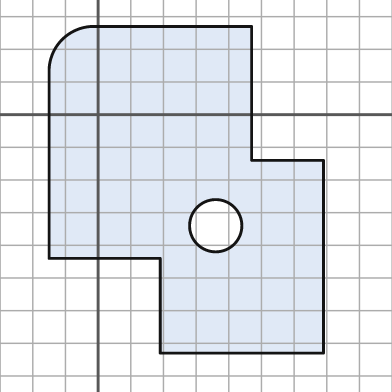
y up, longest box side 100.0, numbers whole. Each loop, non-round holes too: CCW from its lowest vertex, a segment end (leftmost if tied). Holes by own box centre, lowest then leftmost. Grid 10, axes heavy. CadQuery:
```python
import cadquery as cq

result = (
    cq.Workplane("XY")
    .moveTo(19.0, -73.0)
    .lineTo(69.0, -73.0)
    .lineTo(69.0, -14.0)
    .lineTo(47.0, -14.0)
    .lineTo(47.0, 27.0)
    .lineTo(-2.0, 27.0)
    .threePointArc((-11.0, 23.0), (-15.0, 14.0))
    .lineTo(-15.0, -44.0)
    .lineTo(19.0, -44.0)
    .close()
    .moveTo(36.0, -34.0)
    .circle(8.0)
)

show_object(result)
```